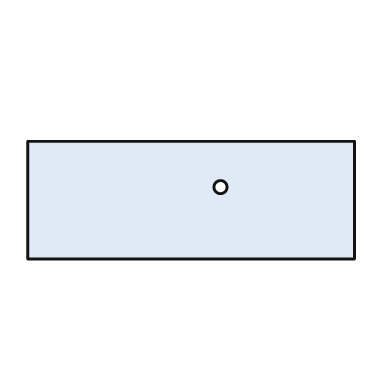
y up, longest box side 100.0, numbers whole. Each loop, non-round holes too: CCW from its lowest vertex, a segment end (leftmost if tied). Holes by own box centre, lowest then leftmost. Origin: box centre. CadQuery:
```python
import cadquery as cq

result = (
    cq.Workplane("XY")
    .moveTo(-50.0, -18.0)
    .lineTo(50.0, -18.0)
    .lineTo(50.0, 18.0)
    .lineTo(-50.0, 18.0)
    .close()
    .moveTo(9.0, 4.0)
    .circle(2.0)
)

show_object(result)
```